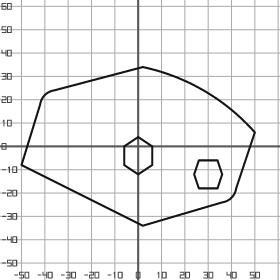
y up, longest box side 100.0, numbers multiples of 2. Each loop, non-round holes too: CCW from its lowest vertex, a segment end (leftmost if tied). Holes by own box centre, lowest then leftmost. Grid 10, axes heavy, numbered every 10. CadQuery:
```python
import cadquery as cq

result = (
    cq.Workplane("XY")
    .moveTo(2.0, -34.0)
    .lineTo(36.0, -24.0)
    .threePointArc((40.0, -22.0), (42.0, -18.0))
    .lineTo(50.0, 6.0)
    .threePointArc((28.0, 24.0), (2.0, 34.0))
    .lineTo(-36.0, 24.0)
    .threePointArc((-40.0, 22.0), (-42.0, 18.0))
    .lineTo(-50.0, -8.0)
    .close()
    .moveTo(26.0, -18.0)
    .lineTo(34.0, -18.0)
    .lineTo(36.0, -12.0)
    .lineTo(34.0, -6.0)
    .lineTo(26.0, -6.0)
    .lineTo(24.0, -12.0)
    .close()
    .moveTo(0.0, -12.0)
    .lineTo(6.0, -8.0)
    .lineTo(6.0, 0.0)
    .lineTo(0.0, 4.0)
    .lineTo(-6.0, 0.0)
    .lineTo(-6.0, -8.0)
    .close()
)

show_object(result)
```